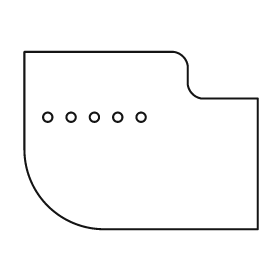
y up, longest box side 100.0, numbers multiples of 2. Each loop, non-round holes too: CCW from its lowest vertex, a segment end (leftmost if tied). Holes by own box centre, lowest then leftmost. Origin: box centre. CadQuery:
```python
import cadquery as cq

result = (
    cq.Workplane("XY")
    .moveTo(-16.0, -38.0)
    .lineTo(50.0, -38.0)
    .lineTo(50.0, 18.0)
    .lineTo(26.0, 18.0)
    .threePointArc((22.0, 20.0), (20.0, 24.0))
    .lineTo(20.0, 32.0)
    .threePointArc((18.0, 36.0), (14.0, 38.0))
    .lineTo(-50.0, 38.0)
    .lineTo(-50.0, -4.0)
    .threePointArc((-40.0, -28.0), (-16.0, -38.0))
    .close()
    .moveTo(-40.0, 10.0)
    .circle(2.0)
    .moveTo(-30.0, 10.0)
    .circle(2.0)
    .moveTo(-20.0, 10.0)
    .circle(2.0)
    .moveTo(-10.0, 10.0)
    .circle(2.0)
    .moveTo(0.0, 10.0)
    .circle(2.0)
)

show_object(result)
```